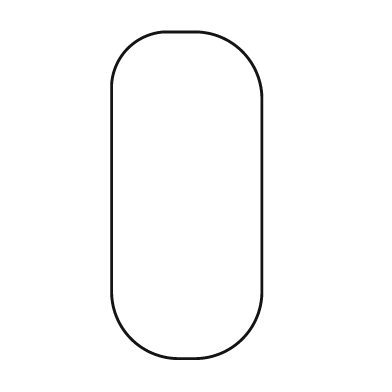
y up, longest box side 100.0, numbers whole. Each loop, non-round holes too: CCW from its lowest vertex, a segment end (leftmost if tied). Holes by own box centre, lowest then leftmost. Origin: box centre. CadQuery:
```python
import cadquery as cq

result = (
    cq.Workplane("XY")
    .moveTo(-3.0, -50.0)
    .lineTo(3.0, -50.0)
    .threePointArc((17.0, -44.0), (23.0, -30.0))
    .lineTo(23.0, 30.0)
    .threePointArc((17.0, 44.0), (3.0, 50.0))
    .lineTo(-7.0, 50.0)
    .threePointArc((-18.0, 45.0), (-23.0, 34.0))
    .lineTo(-23.0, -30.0)
    .threePointArc((-17.0, -44.0), (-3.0, -50.0))
    .close()
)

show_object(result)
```